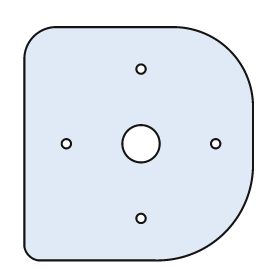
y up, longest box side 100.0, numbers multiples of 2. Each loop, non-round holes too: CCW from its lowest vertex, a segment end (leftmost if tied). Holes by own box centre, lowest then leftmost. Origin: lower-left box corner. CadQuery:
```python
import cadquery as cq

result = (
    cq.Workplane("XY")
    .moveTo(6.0, 0.0)
    .lineTo(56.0, 0.0)
    .threePointArc((86.0, 12.0), (98.0, 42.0))
    .lineTo(98.0, 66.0)
    .threePointArc((88.0, 90.0), (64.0, 100.0))
    .lineTo(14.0, 100.0)
    .threePointArc((4.0, 96.0), (0.0, 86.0))
    .lineTo(0.0, 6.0)
    .threePointArc((2.0, 2.0), (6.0, 0.0))
    .close()
    .moveTo(50.0, 18.0)
    .circle(2.0)
    .moveTo(18.0, 50.0)
    .circle(2.0)
    .moveTo(50.0, 50.0)
    .circle(8.0)
    .moveTo(82.0, 50.0)
    .circle(2.0)
    .moveTo(50.0, 82.0)
    .circle(2.0)
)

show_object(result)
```